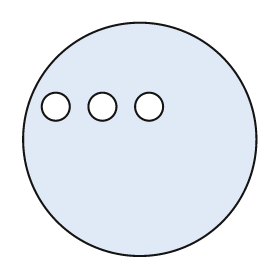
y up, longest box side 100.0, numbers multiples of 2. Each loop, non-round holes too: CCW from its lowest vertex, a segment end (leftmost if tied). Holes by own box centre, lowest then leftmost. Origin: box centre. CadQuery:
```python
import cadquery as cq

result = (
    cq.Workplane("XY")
    .moveTo(0.0, 0.0)
    .circle(50.0)
    .moveTo(-36.0, 14.0)
    .circle(6.0)
    .moveTo(-16.0, 14.0)
    .circle(6.0)
    .moveTo(4.0, 14.0)
    .circle(6.0)
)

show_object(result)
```